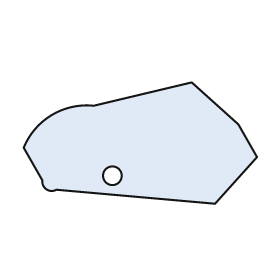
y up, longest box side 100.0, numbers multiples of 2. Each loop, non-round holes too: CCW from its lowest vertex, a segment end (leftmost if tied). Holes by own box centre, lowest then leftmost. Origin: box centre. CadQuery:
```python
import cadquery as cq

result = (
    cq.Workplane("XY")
    .moveTo(32.0, -26.0)
    .lineTo(50.0, -6.0)
    .lineTo(42.0, 8.0)
    .lineTo(22.0, 26.0)
    .lineTo(-20.0, 16.0)
    .threePointArc((-38.0, 12.0), (-50.0, -2.0))
    .lineTo(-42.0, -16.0)
    .threePointArc((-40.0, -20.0), (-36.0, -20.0))
    .close()
    .moveTo(-12.0, -14.0)
    .circle(4.0)
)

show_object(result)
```